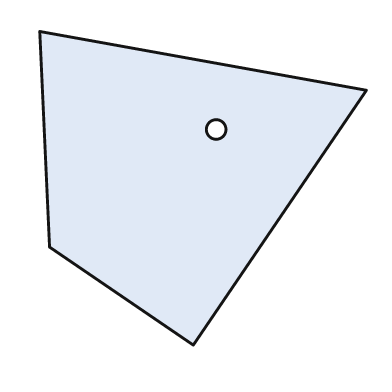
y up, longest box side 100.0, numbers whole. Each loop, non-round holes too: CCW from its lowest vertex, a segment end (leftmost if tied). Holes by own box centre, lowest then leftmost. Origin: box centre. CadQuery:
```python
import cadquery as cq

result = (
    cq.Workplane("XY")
    .moveTo(-3.0, -48.0)
    .lineTo(50.0, 30.0)
    .lineTo(-50.0, 48.0)
    .lineTo(-47.0, -18.0)
    .close()
    .moveTo(4.0, 18.0)
    .circle(3.0)
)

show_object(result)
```